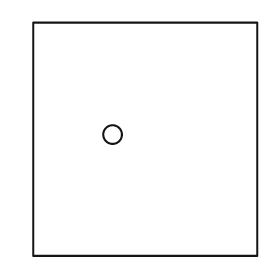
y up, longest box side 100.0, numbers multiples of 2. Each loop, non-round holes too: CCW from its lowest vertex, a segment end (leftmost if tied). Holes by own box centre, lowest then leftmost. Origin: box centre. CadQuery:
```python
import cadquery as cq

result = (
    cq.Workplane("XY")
    .moveTo(-48.0, -50.0)
    .lineTo(48.0, -50.0)
    .lineTo(48.0, 50.0)
    .lineTo(-48.0, 50.0)
    .close()
    .moveTo(-14.0, 2.0)
    .circle(4.0)
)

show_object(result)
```